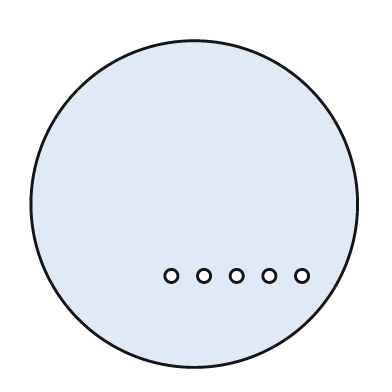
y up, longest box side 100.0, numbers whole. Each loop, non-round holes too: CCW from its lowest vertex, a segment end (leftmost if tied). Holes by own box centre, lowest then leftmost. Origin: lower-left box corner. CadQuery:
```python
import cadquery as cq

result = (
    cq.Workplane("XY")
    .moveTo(50.0, 50.0)
    .circle(50.0)
    .moveTo(43.0, 28.0)
    .circle(2.0)
    .moveTo(53.0, 28.0)
    .circle(2.0)
    .moveTo(63.0, 28.0)
    .circle(2.0)
    .moveTo(73.0, 28.0)
    .circle(2.0)
    .moveTo(83.0, 28.0)
    .circle(2.0)
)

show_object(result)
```